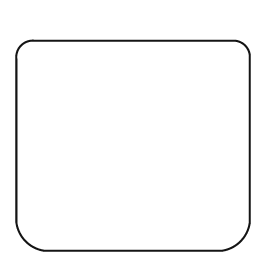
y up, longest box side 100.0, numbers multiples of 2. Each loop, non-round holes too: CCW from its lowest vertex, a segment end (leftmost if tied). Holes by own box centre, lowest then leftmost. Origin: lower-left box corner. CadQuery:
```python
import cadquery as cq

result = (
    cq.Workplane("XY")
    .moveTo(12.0, 0.0)
    .lineTo(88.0, 0.0)
    .threePointArc((96.0, 4.0), (100.0, 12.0))
    .lineTo(100.0, 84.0)
    .threePointArc((98.0, 88.0), (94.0, 90.0))
    .lineTo(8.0, 90.0)
    .threePointArc((2.0, 88.0), (0.0, 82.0))
    .lineTo(0.0, 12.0)
    .threePointArc((4.0, 4.0), (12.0, 0.0))
    .close()
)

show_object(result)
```